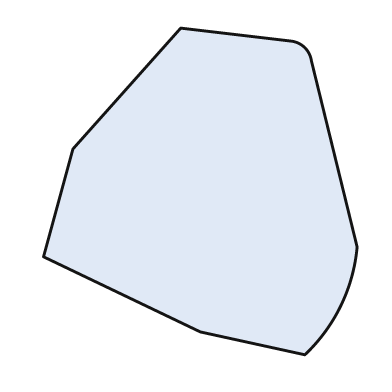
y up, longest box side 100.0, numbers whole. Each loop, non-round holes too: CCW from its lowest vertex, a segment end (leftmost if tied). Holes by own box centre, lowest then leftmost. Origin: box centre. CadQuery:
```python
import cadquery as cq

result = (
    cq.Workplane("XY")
    .moveTo(32.0, -50.0)
    .threePointArc((43.0, -35.0), (48.0, -17.0))
    .lineTo(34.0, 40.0)
    .threePointArc((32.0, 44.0), (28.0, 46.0))
    .lineTo(-6.0, 50.0)
    .lineTo(-39.0, 13.0)
    .lineTo(-48.0, -20.0)
    .lineTo(0.0, -43.0)
    .close()
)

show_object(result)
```